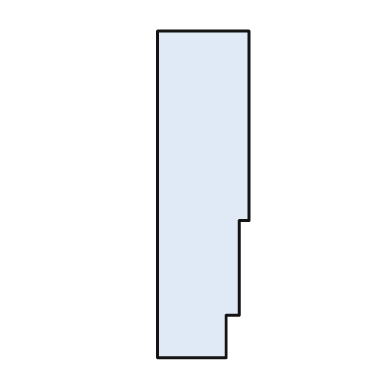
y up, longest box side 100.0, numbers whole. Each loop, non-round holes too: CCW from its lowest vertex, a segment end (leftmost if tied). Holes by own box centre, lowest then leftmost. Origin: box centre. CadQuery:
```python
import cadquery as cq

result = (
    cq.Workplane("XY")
    .moveTo(-14.0, -50.0)
    .lineTo(7.0, -50.0)
    .lineTo(7.0, -37.0)
    .lineTo(11.0, -37.0)
    .lineTo(11.0, -8.0)
    .lineTo(14.0, -8.0)
    .lineTo(14.0, 50.0)
    .lineTo(-14.0, 50.0)
    .close()
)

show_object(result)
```